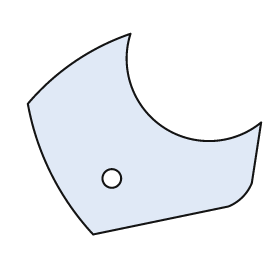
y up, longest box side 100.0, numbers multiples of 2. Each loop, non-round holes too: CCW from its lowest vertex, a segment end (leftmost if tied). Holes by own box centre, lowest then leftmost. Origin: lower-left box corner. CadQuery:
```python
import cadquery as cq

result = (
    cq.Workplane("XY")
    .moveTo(28.0, 0.0)
    .lineTo(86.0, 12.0)
    .threePointArc((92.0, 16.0), (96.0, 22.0))
    .lineTo(100.0, 48.0)
    .threePointArc((58.0, 46.0), (44.0, 86.0))
    .threePointArc((20.0, 74.0), (0.0, 56.0))
    .threePointArc((10.0, 26.0), (28.0, 0.0))
    .close()
    .moveTo(36.0, 24.0)
    .circle(4.0)
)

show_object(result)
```